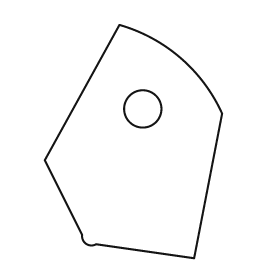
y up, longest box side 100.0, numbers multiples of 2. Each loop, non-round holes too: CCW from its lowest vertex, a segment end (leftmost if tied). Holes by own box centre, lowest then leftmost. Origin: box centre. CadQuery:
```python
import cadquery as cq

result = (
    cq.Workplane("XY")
    .moveTo(26.0, -50.0)
    .lineTo(38.0, 12.0)
    .threePointArc((20.0, 36.0), (-6.0, 50.0))
    .lineTo(-38.0, -8.0)
    .lineTo(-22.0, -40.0)
    .threePointArc((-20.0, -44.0), (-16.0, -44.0))
    .close()
    .moveTo(4.0, 14.0)
    .circle(8.0)
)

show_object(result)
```